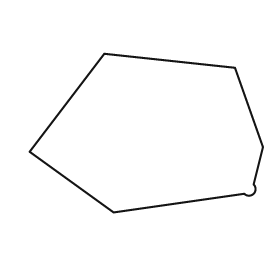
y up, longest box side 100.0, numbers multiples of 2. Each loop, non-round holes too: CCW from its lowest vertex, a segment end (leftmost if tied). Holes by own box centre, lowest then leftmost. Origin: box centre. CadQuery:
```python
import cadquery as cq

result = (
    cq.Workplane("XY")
    .moveTo(-14.0, -34.0)
    .lineTo(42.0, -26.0)
    .threePointArc((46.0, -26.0), (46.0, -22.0))
    .lineTo(50.0, -6.0)
    .lineTo(38.0, 28.0)
    .lineTo(-18.0, 34.0)
    .lineTo(-50.0, -8.0)
    .close()
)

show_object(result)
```